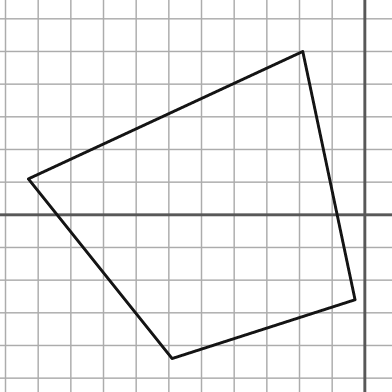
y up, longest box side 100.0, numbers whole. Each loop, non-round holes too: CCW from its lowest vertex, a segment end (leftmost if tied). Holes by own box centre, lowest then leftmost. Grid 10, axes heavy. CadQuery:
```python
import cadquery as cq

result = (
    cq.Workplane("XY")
    .moveTo(-59.0, -44.0)
    .lineTo(-3.0, -26.0)
    .lineTo(-19.0, 50.0)
    .lineTo(-103.0, 11.0)
    .close()
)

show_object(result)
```